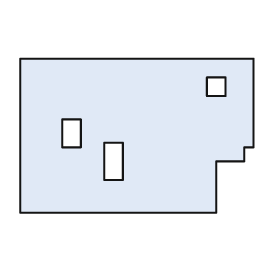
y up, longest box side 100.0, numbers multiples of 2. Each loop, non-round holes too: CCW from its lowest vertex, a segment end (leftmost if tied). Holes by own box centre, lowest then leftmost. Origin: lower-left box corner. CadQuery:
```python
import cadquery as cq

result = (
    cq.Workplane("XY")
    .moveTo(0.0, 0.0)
    .lineTo(84.0, 0.0)
    .lineTo(84.0, 22.0)
    .lineTo(96.0, 22.0)
    .lineTo(96.0, 28.0)
    .lineTo(100.0, 28.0)
    .lineTo(100.0, 66.0)
    .lineTo(0.0, 66.0)
    .close()
    .moveTo(36.0, 14.0)
    .lineTo(44.0, 14.0)
    .lineTo(44.0, 30.0)
    .lineTo(36.0, 30.0)
    .close()
    .moveTo(18.0, 28.0)
    .lineTo(26.0, 28.0)
    .lineTo(26.0, 40.0)
    .lineTo(18.0, 40.0)
    .close()
    .moveTo(80.0, 50.0)
    .lineTo(88.0, 50.0)
    .lineTo(88.0, 58.0)
    .lineTo(80.0, 58.0)
    .close()
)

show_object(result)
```